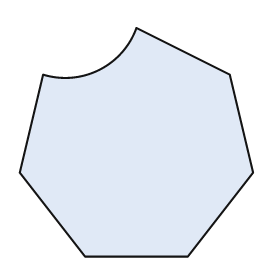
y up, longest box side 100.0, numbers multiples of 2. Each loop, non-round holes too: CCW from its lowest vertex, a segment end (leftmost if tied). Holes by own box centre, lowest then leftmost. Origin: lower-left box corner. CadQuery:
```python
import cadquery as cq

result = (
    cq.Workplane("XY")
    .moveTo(28.0, 0.0)
    .lineTo(72.0, 0.0)
    .lineTo(100.0, 36.0)
    .lineTo(90.0, 78.0)
    .lineTo(50.0, 98.0)
    .threePointArc((34.0, 80.0), (10.0, 78.0))
    .lineTo(0.0, 36.0)
    .close()
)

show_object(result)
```